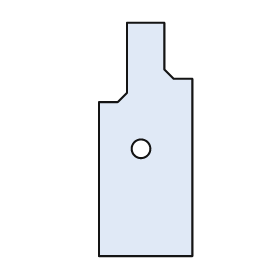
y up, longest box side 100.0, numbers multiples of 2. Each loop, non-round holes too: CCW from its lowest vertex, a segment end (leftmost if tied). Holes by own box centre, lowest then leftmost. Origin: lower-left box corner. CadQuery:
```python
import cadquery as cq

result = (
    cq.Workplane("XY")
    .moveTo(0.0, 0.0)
    .lineTo(40.0, 0.0)
    .lineTo(40.0, 76.0)
    .lineTo(32.0, 76.0)
    .lineTo(28.0, 80.0)
    .lineTo(28.0, 100.0)
    .lineTo(12.0, 100.0)
    .lineTo(12.0, 70.0)
    .lineTo(8.0, 66.0)
    .lineTo(0.0, 66.0)
    .close()
    .moveTo(18.0, 46.0)
    .circle(4.0)
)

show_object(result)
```